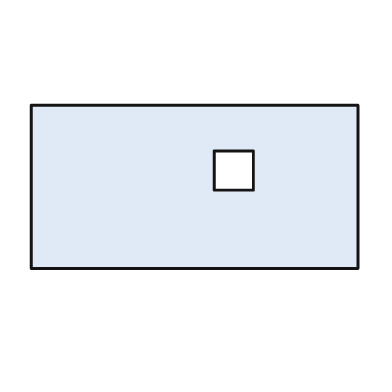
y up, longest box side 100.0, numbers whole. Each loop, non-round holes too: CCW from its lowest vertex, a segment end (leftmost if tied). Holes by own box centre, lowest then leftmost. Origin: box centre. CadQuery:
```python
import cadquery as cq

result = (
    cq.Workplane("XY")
    .moveTo(-50.0, -25.0)
    .lineTo(50.0, -25.0)
    .lineTo(50.0, 25.0)
    .lineTo(-50.0, 25.0)
    .close()
    .moveTo(6.0, -1.0)
    .lineTo(18.0, -1.0)
    .lineTo(18.0, 11.0)
    .lineTo(6.0, 11.0)
    .close()
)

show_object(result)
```